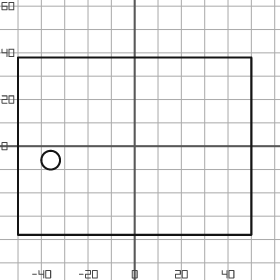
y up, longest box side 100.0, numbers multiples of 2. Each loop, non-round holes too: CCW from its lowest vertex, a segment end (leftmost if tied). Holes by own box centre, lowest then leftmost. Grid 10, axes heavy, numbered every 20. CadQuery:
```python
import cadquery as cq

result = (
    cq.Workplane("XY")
    .moveTo(-50.0, -38.0)
    .lineTo(50.0, -38.0)
    .lineTo(50.0, 38.0)
    .lineTo(-50.0, 38.0)
    .close()
    .moveTo(-36.0, -6.0)
    .circle(4.0)
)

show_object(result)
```